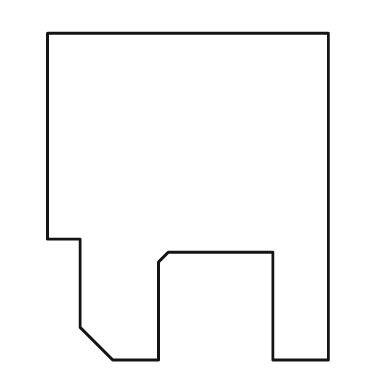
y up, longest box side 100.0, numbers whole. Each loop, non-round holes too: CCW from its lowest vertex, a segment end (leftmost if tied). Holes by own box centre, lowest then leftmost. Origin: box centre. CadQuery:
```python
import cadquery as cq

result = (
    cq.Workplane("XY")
    .moveTo(-23.0, -50.0)
    .lineTo(-9.0, -50.0)
    .lineTo(-9.0, -20.0)
    .lineTo(-6.0, -17.0)
    .lineTo(26.0, -17.0)
    .lineTo(26.0, -50.0)
    .lineTo(43.0, -50.0)
    .lineTo(43.0, 50.0)
    .lineTo(-43.0, 50.0)
    .lineTo(-43.0, -13.0)
    .lineTo(-33.0, -13.0)
    .lineTo(-33.0, -40.0)
    .close()
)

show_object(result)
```